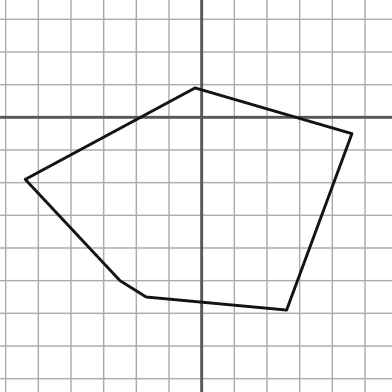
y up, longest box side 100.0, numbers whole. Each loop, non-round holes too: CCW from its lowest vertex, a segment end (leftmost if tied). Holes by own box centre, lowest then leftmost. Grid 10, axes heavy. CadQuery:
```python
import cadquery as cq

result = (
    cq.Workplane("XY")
    .moveTo(26.0, -59.0)
    .lineTo(46.0, -5.0)
    .lineTo(-2.0, 9.0)
    .lineTo(-54.0, -19.0)
    .lineTo(-25.0, -50.0)
    .lineTo(-17.0, -55.0)
    .close()
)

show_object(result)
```